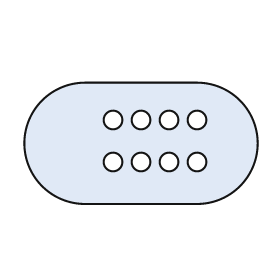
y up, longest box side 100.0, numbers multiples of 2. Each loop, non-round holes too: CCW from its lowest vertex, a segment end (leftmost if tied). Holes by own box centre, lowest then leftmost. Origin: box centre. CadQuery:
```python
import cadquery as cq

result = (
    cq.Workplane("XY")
    .moveTo(-24.0, -26.0)
    .lineTo(24.0, -26.0)
    .threePointArc((50.0, 0.0), (24.0, 26.0))
    .lineTo(-24.0, 26.0)
    .threePointArc((-50.0, 0.0), (-24.0, -26.0))
    .close()
    .moveTo(-12.0, -8.0)
    .circle(4.0)
    .moveTo(0.0, -8.0)
    .circle(4.0)
    .moveTo(12.0, -8.0)
    .circle(4.0)
    .moveTo(24.0, -8.0)
    .circle(4.0)
    .moveTo(-12.0, 10.0)
    .circle(4.0)
    .moveTo(0.0, 10.0)
    .circle(4.0)
    .moveTo(12.0, 10.0)
    .circle(4.0)
    .moveTo(24.0, 10.0)
    .circle(4.0)
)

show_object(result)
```